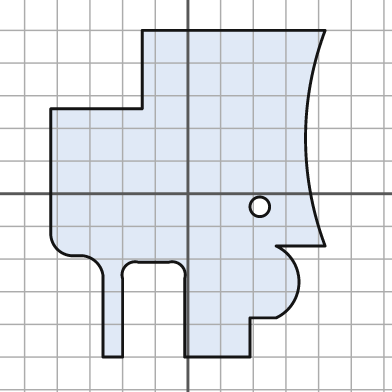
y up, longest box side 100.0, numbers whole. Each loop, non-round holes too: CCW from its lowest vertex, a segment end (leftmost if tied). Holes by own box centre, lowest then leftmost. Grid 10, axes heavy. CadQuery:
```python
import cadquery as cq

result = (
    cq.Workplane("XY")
    .moveTo(-26.0, -50.0)
    .lineTo(-20.0, -50.0)
    .lineTo(-20.0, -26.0)
    .threePointArc((-19.0, -22.0), (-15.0, -21.0))
    .lineTo(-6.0, -21.0)
    .threePointArc((-2.0, -22.0), (-1.0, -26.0))
    .lineTo(-1.0, -50.0)
    .lineTo(19.0, -50.0)
    .lineTo(19.0, -38.0)
    .lineTo(27.0, -38.0)
    .threePointArc((34.0, -27.0), (27.0, -16.0))
    .lineTo(42.0, -16.0)
    .threePointArc((36.0, 17.0), (42.0, 50.0))
    .lineTo(-14.0, 50.0)
    .lineTo(-14.0, 26.0)
    .lineTo(-42.0, 26.0)
    .lineTo(-42.0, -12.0)
    .threePointArc((-40.0, -17.0), (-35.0, -19.0))
    .lineTo(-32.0, -19.0)
    .threePointArc((-28.0, -21.0), (-26.0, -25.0))
    .close()
    .moveTo(22.0, -4.0)
    .circle(3.0)
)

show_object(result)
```